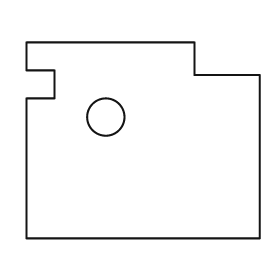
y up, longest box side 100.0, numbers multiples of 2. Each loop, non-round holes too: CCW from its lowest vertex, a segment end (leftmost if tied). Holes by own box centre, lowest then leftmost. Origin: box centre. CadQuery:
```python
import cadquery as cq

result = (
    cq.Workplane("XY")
    .moveTo(-50.0, -42.0)
    .lineTo(50.0, -42.0)
    .lineTo(50.0, 28.0)
    .lineTo(22.0, 28.0)
    .lineTo(22.0, 42.0)
    .lineTo(-50.0, 42.0)
    .lineTo(-50.0, 30.0)
    .lineTo(-38.0, 30.0)
    .lineTo(-38.0, 18.0)
    .lineTo(-50.0, 18.0)
    .close()
    .moveTo(-16.0, 10.0)
    .circle(8.0)
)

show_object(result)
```